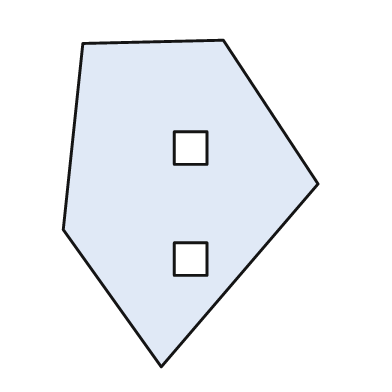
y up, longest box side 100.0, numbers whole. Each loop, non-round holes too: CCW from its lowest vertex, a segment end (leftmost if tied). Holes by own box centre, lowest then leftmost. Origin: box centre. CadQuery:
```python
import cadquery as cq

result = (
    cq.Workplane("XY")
    .moveTo(-9.0, -50.0)
    .lineTo(39.0, 6.0)
    .lineTo(10.0, 50.0)
    .lineTo(-33.0, 49.0)
    .lineTo(-39.0, -8.0)
    .close()
    .moveTo(-5.0, -22.0)
    .lineTo(5.0, -22.0)
    .lineTo(5.0, -12.0)
    .lineTo(-5.0, -12.0)
    .close()
    .moveTo(-5.0, 12.0)
    .lineTo(5.0, 12.0)
    .lineTo(5.0, 22.0)
    .lineTo(-5.0, 22.0)
    .close()
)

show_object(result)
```